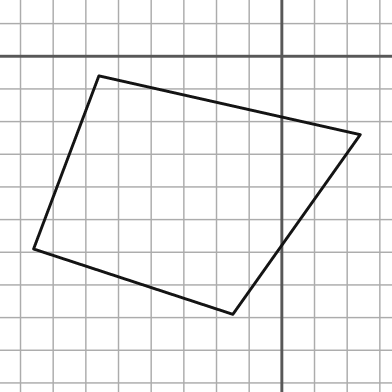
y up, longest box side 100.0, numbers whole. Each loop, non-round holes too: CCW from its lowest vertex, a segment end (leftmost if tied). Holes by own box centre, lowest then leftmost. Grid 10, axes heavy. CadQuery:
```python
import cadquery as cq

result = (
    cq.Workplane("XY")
    .moveTo(-15.0, -79.0)
    .lineTo(24.0, -24.0)
    .lineTo(-56.0, -6.0)
    .lineTo(-76.0, -59.0)
    .close()
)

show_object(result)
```